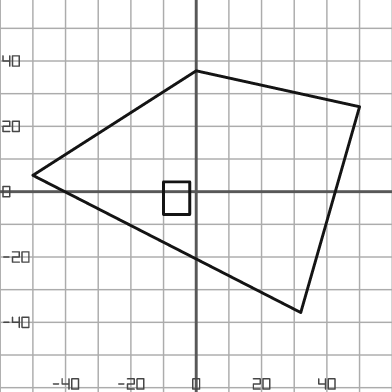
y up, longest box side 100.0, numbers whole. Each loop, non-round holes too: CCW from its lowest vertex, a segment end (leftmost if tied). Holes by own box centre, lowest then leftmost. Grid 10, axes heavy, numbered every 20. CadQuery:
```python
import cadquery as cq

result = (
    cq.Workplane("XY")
    .moveTo(32.0, -37.0)
    .lineTo(50.0, 26.0)
    .lineTo(0.0, 37.0)
    .lineTo(-50.0, 5.0)
    .close()
    .moveTo(-10.0, -7.0)
    .lineTo(-2.0, -7.0)
    .lineTo(-2.0, 3.0)
    .lineTo(-10.0, 3.0)
    .close()
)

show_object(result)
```